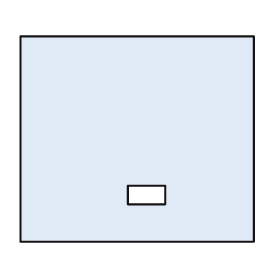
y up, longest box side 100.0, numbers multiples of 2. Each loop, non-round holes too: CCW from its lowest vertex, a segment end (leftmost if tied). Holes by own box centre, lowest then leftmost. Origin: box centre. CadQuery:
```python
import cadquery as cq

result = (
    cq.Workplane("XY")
    .moveTo(-50.0, -44.0)
    .lineTo(50.0, -44.0)
    .lineTo(50.0, 44.0)
    .lineTo(-50.0, 44.0)
    .close()
    .moveTo(-4.0, -28.0)
    .lineTo(12.0, -28.0)
    .lineTo(12.0, -20.0)
    .lineTo(-4.0, -20.0)
    .close()
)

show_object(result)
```